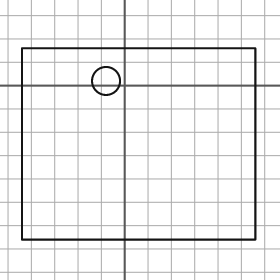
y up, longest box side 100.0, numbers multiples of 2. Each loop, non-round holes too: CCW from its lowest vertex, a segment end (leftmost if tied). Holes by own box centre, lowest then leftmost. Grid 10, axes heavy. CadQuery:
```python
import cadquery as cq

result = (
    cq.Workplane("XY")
    .moveTo(-44.0, -66.0)
    .lineTo(56.0, -66.0)
    .lineTo(56.0, 16.0)
    .lineTo(-44.0, 16.0)
    .close()
    .moveTo(-8.0, 2.0)
    .circle(6.0)
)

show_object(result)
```